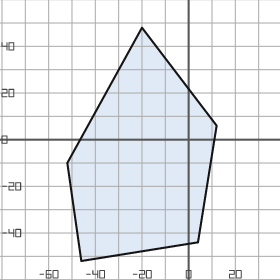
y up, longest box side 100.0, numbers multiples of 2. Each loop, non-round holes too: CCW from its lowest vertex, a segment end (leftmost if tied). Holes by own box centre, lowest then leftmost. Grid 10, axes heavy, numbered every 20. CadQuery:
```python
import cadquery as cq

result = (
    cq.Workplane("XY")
    .moveTo(-46.0, -52.0)
    .lineTo(4.0, -44.0)
    .lineTo(12.0, 6.0)
    .lineTo(-20.0, 48.0)
    .lineTo(-52.0, -10.0)
    .close()
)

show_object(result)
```